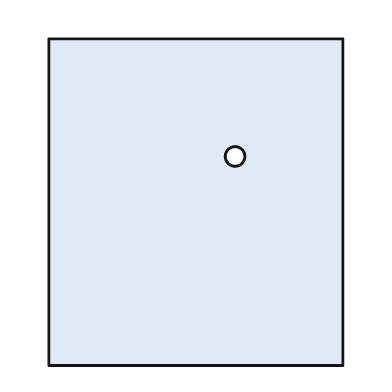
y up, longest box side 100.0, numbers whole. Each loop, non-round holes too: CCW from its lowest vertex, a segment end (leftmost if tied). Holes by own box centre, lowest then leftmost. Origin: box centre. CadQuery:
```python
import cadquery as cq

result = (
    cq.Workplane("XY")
    .moveTo(-45.0, -50.0)
    .lineTo(45.0, -50.0)
    .lineTo(45.0, 50.0)
    .lineTo(-45.0, 50.0)
    .close()
    .moveTo(12.0, 14.0)
    .circle(3.0)
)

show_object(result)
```